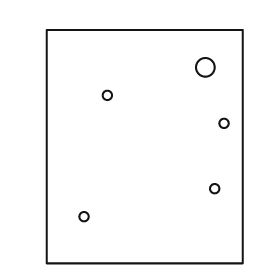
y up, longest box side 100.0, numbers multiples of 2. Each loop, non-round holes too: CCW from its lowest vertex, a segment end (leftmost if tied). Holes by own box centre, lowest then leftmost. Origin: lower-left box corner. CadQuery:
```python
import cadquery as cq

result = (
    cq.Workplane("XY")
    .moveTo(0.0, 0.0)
    .lineTo(84.0, 0.0)
    .lineTo(84.0, 100.0)
    .lineTo(0.0, 100.0)
    .close()
    .moveTo(16.0, 20.0)
    .circle(2.0)
    .moveTo(72.0, 32.0)
    .circle(2.0)
    .moveTo(76.0, 60.0)
    .circle(2.0)
    .moveTo(26.0, 72.0)
    .circle(2.0)
    .moveTo(68.0, 84.0)
    .circle(4.0)
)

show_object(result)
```